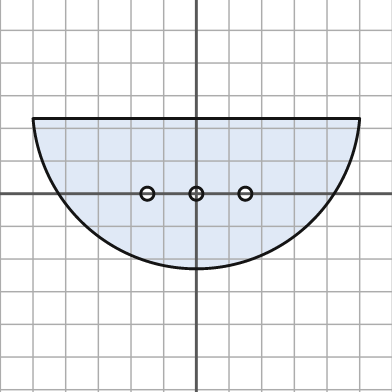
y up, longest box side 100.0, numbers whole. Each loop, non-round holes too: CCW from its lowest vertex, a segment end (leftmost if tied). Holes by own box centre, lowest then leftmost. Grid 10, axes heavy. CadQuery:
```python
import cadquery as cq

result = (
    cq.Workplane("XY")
    .moveTo(-50.0, 23.0)
    .threePointArc((0.0, -23.0), (50.0, 23.0))
    .close()
    .moveTo(-15.0, 0.0)
    .circle(2.0)
    .moveTo(0.0, 0.0)
    .circle(2.0)
    .moveTo(15.0, 0.0)
    .circle(2.0)
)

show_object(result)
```